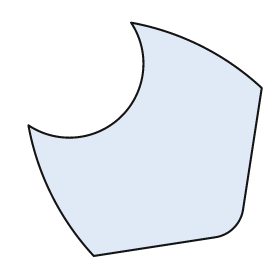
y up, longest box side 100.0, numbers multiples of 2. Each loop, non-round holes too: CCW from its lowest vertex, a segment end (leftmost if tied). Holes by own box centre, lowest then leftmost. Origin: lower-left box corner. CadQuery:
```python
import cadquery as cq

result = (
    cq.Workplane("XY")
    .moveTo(28.0, 0.0)
    .lineTo(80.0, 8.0)
    .threePointArc((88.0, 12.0), (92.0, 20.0))
    .lineTo(100.0, 72.0)
    .threePointArc((74.0, 90.0), (44.0, 100.0))
    .threePointArc((40.0, 60.0), (0.0, 56.0))
    .threePointArc((10.0, 26.0), (28.0, 0.0))
    .close()
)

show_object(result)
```